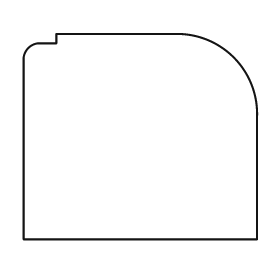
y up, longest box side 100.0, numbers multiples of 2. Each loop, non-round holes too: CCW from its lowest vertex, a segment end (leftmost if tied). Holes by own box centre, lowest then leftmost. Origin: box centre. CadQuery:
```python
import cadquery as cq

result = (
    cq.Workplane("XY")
    .moveTo(-50.0, -44.0)
    .lineTo(50.0, -44.0)
    .lineTo(50.0, 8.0)
    .threePointArc((40.0, 34.0), (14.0, 44.0))
    .lineTo(-36.0, 44.0)
    .lineTo(-36.0, 40.0)
    .lineTo(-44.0, 40.0)
    .threePointArc((-48.0, 38.0), (-50.0, 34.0))
    .close()
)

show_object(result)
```